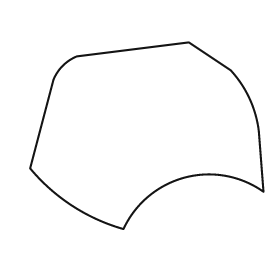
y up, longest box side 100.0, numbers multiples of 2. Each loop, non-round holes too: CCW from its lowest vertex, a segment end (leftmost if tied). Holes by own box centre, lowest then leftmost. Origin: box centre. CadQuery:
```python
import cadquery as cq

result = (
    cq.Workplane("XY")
    .moveTo(-10.0, -40.0)
    .threePointArc((16.0, -18.0), (50.0, -24.0))
    .lineTo(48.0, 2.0)
    .threePointArc((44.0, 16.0), (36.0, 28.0))
    .lineTo(18.0, 40.0)
    .lineTo(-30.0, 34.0)
    .threePointArc((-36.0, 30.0), (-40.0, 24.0))
    .lineTo(-50.0, -14.0)
    .threePointArc((-32.0, -30.0), (-10.0, -40.0))
    .close()
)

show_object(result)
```